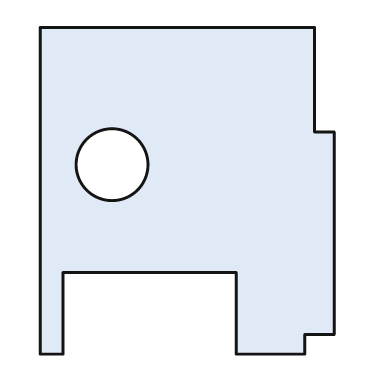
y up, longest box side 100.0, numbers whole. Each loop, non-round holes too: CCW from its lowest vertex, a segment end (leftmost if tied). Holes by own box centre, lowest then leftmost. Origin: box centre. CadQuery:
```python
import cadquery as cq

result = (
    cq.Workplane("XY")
    .moveTo(-45.0, -50.0)
    .lineTo(-38.0, -50.0)
    .lineTo(-38.0, -25.0)
    .lineTo(15.0, -25.0)
    .lineTo(15.0, -50.0)
    .lineTo(36.0, -50.0)
    .lineTo(36.0, -44.0)
    .lineTo(45.0, -44.0)
    .lineTo(45.0, 18.0)
    .lineTo(39.0, 18.0)
    .lineTo(39.0, 50.0)
    .lineTo(-45.0, 50.0)
    .close()
    .moveTo(-23.0, 8.0)
    .circle(11.0)
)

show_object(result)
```